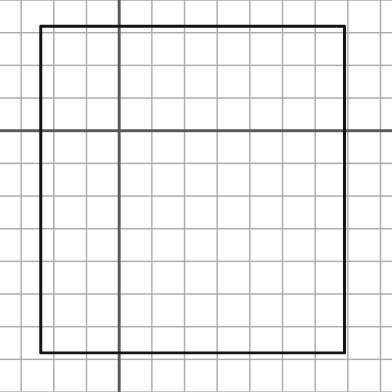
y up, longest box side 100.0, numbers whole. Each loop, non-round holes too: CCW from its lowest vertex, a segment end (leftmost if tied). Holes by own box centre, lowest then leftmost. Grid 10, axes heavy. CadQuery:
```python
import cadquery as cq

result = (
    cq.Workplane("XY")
    .moveTo(-24.0, -68.0)
    .lineTo(69.0, -68.0)
    .lineTo(69.0, 32.0)
    .lineTo(-24.0, 32.0)
    .close()
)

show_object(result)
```